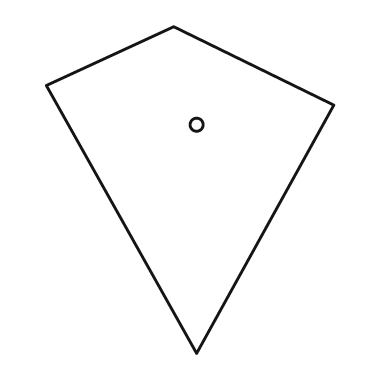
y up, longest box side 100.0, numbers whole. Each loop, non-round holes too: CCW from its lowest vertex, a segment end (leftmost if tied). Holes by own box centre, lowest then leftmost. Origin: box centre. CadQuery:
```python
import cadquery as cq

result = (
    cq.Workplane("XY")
    .moveTo(2.0, -50.0)
    .lineTo(44.0, 26.0)
    .lineTo(-5.0, 50.0)
    .lineTo(-44.0, 32.0)
    .close()
    .moveTo(2.0, 20.0)
    .circle(2.0)
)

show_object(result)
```